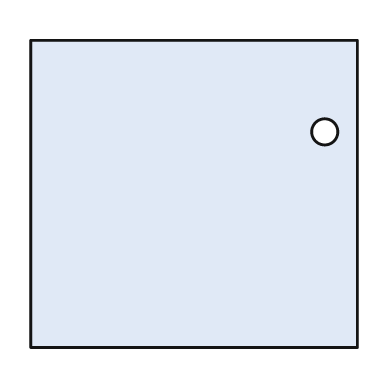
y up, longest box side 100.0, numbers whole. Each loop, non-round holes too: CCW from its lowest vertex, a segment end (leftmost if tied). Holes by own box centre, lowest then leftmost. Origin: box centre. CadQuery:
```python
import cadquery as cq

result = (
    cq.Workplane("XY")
    .moveTo(-50.0, -47.0)
    .lineTo(50.0, -47.0)
    .lineTo(50.0, 47.0)
    .lineTo(-50.0, 47.0)
    .close()
    .moveTo(40.0, 19.0)
    .circle(4.0)
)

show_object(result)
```